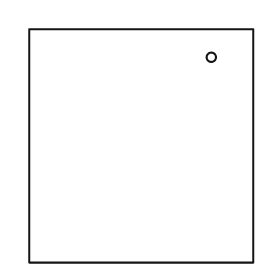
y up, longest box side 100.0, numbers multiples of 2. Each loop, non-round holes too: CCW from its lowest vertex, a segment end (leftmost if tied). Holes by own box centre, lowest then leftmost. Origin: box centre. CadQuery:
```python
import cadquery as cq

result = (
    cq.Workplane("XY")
    .moveTo(-48.0, -50.0)
    .lineTo(48.0, -50.0)
    .lineTo(48.0, 50.0)
    .lineTo(-48.0, 50.0)
    .close()
    .moveTo(30.0, 38.0)
    .circle(2.0)
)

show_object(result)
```